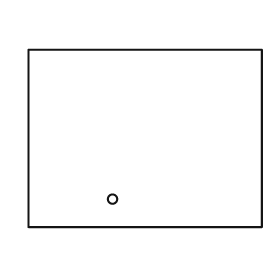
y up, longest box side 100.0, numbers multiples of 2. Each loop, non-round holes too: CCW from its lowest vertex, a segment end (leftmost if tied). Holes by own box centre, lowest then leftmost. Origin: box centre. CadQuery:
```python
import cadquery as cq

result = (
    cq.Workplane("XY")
    .moveTo(-50.0, -38.0)
    .lineTo(50.0, -38.0)
    .lineTo(50.0, 38.0)
    .lineTo(-50.0, 38.0)
    .close()
    .moveTo(-14.0, -26.0)
    .circle(2.0)
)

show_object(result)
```